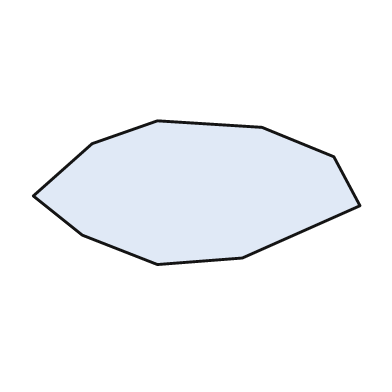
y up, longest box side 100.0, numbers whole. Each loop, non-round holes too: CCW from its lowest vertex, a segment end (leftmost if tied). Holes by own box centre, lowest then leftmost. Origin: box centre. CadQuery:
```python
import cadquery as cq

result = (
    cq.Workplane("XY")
    .moveTo(-12.0, -22.0)
    .lineTo(14.0, -20.0)
    .lineTo(50.0, -4.0)
    .lineTo(42.0, 11.0)
    .lineTo(20.0, 20.0)
    .lineTo(-12.0, 22.0)
    .lineTo(-32.0, 15.0)
    .lineTo(-50.0, -1.0)
    .lineTo(-35.0, -13.0)
    .close()
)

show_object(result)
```